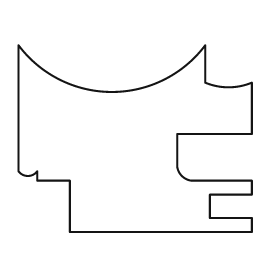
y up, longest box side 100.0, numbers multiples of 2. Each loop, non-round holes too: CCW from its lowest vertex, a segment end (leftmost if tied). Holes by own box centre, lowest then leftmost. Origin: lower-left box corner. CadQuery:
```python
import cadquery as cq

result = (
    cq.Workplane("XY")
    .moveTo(22.0, 0.0)
    .lineTo(100.0, 0.0)
    .lineTo(100.0, 6.0)
    .lineTo(82.0, 6.0)
    .lineTo(82.0, 16.0)
    .lineTo(100.0, 16.0)
    .lineTo(100.0, 22.0)
    .lineTo(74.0, 22.0)
    .threePointArc((70.0, 24.0), (68.0, 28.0))
    .lineTo(68.0, 42.0)
    .lineTo(100.0, 42.0)
    .lineTo(100.0, 64.0)
    .threePointArc((90.0, 62.0), (80.0, 64.0))
    .lineTo(80.0, 80.0)
    .threePointArc((40.0, 60.0), (0.0, 80.0))
    .lineTo(0.0, 26.0)
    .threePointArc((4.0, 24.0), (8.0, 26.0))
    .lineTo(8.0, 22.0)
    .lineTo(22.0, 22.0)
    .close()
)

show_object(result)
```